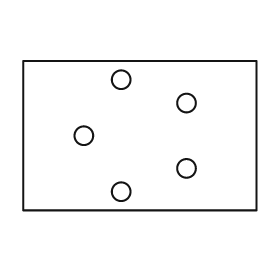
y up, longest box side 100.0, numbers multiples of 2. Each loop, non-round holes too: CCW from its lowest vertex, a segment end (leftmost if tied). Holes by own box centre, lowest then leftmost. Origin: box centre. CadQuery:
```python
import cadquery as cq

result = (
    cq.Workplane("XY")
    .moveTo(-50.0, -32.0)
    .lineTo(50.0, -32.0)
    .lineTo(50.0, 32.0)
    .lineTo(-50.0, 32.0)
    .close()
    .moveTo(-8.0, -24.0)
    .circle(4.0)
    .moveTo(20.0, -14.0)
    .circle(4.0)
    .moveTo(-24.0, 0.0)
    .circle(4.0)
    .moveTo(20.0, 14.0)
    .circle(4.0)
    .moveTo(-8.0, 24.0)
    .circle(4.0)
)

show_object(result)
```